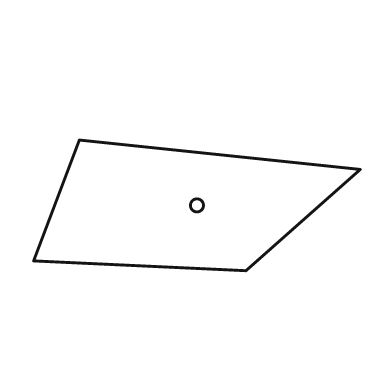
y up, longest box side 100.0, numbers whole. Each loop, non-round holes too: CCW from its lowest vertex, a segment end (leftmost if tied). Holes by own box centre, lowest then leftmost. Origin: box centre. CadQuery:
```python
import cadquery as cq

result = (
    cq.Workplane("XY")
    .moveTo(15.0, -20.0)
    .lineTo(50.0, 11.0)
    .lineTo(-36.0, 20.0)
    .lineTo(-50.0, -17.0)
    .close()
    .moveTo(0.0, 0.0)
    .circle(2.0)
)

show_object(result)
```